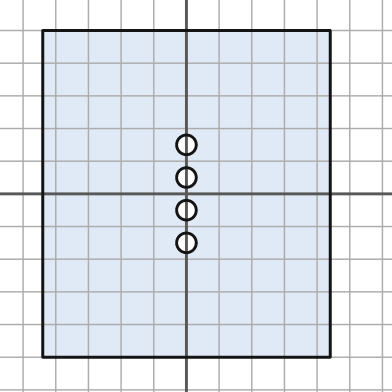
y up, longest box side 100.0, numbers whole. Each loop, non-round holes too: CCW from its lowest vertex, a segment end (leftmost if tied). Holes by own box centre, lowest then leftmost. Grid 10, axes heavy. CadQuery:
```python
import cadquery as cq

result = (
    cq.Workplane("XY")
    .moveTo(-44.0, -50.0)
    .lineTo(44.0, -50.0)
    .lineTo(44.0, 50.0)
    .lineTo(-44.0, 50.0)
    .close()
    .moveTo(0.0, -15.0)
    .circle(3.0)
    .moveTo(0.0, -5.0)
    .circle(3.0)
    .moveTo(0.0, 5.0)
    .circle(3.0)
    .moveTo(0.0, 15.0)
    .circle(3.0)
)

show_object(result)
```